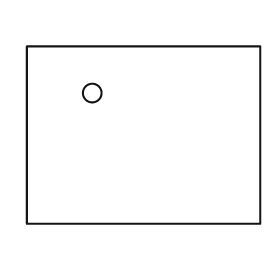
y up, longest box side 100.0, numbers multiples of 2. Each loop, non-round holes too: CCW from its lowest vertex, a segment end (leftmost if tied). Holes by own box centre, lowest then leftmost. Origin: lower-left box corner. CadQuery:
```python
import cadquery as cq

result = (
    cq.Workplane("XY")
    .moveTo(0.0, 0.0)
    .lineTo(100.0, 0.0)
    .lineTo(100.0, 76.0)
    .lineTo(0.0, 76.0)
    .close()
    .moveTo(28.0, 56.0)
    .circle(4.0)
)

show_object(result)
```